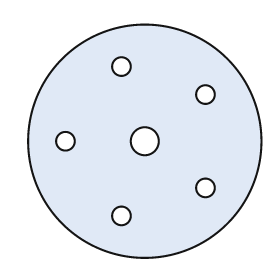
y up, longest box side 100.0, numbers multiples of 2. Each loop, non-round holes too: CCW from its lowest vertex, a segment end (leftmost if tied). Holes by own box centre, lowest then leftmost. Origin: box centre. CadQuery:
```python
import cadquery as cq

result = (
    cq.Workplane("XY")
    .moveTo(0.0, 0.0)
    .circle(50.0)
    .moveTo(-10.0, -32.0)
    .circle(4.0)
    .moveTo(26.0, -20.0)
    .circle(4.0)
    .moveTo(-34.0, 0.0)
    .circle(4.0)
    .moveTo(0.0, 0.0)
    .circle(6.0)
    .moveTo(26.0, 20.0)
    .circle(4.0)
    .moveTo(-10.0, 32.0)
    .circle(4.0)
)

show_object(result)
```